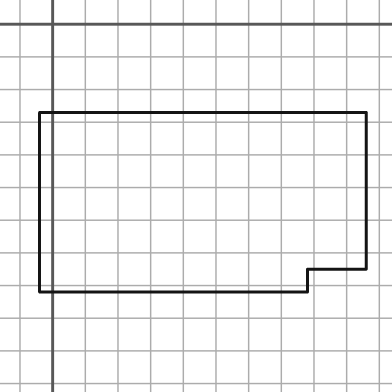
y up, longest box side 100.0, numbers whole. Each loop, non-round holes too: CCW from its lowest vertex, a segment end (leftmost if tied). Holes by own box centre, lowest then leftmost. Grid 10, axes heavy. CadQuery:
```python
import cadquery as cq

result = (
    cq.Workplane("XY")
    .moveTo(-4.0, -82.0)
    .lineTo(78.0, -82.0)
    .lineTo(78.0, -75.0)
    .lineTo(96.0, -75.0)
    .lineTo(96.0, -27.0)
    .lineTo(-4.0, -27.0)
    .close()
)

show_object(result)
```